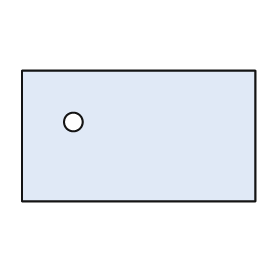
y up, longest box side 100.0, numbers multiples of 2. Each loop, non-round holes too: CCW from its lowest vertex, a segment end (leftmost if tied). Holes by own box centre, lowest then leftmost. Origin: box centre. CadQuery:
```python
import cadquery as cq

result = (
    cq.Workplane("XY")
    .moveTo(-50.0, -28.0)
    .lineTo(50.0, -28.0)
    .lineTo(50.0, 28.0)
    .lineTo(-50.0, 28.0)
    .close()
    .moveTo(-28.0, 6.0)
    .circle(4.0)
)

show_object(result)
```